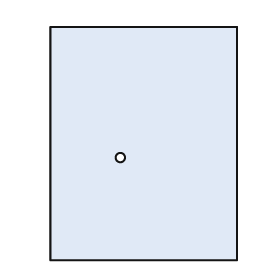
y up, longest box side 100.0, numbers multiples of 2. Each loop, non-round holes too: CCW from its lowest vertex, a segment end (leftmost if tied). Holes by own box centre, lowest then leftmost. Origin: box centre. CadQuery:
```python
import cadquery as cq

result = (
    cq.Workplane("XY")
    .moveTo(-40.0, -50.0)
    .lineTo(40.0, -50.0)
    .lineTo(40.0, 50.0)
    .lineTo(-40.0, 50.0)
    .close()
    .moveTo(-10.0, -6.0)
    .circle(2.0)
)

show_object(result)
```